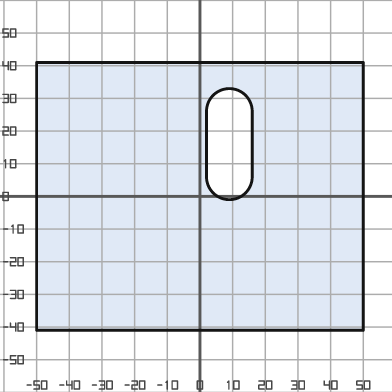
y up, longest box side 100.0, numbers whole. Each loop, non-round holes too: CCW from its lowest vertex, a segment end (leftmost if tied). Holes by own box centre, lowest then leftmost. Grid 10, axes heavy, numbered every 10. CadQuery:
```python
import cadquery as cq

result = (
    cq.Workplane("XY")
    .moveTo(-50.0, -41.0)
    .lineTo(50.0, -41.0)
    .lineTo(50.0, 41.0)
    .lineTo(-50.0, 41.0)
    .close()
    .moveTo(2.0, 6.0)
    .threePointArc((9.0, -1.0), (16.0, 6.0))
    .lineTo(16.0, 26.0)
    .threePointArc((9.0, 33.0), (2.0, 26.0))
    .close()
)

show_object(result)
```